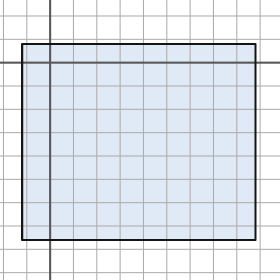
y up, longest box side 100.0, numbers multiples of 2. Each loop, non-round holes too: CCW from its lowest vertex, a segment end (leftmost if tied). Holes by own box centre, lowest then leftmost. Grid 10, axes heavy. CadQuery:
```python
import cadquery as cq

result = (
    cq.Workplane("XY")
    .moveTo(-12.0, -76.0)
    .lineTo(88.0, -76.0)
    .lineTo(88.0, 8.0)
    .lineTo(-12.0, 8.0)
    .close()
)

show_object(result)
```